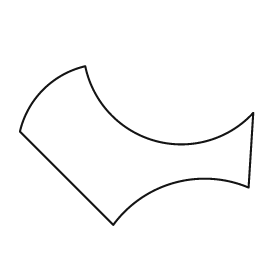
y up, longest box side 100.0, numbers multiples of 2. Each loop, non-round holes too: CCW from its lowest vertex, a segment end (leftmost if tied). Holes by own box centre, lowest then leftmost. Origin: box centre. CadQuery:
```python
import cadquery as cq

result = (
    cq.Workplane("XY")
    .moveTo(-10.0, -34.0)
    .threePointArc((16.0, -16.0), (48.0, -18.0))
    .lineTo(50.0, 14.0)
    .threePointArc((8.0, 2.0), (-22.0, 34.0))
    .threePointArc((-40.0, 24.0), (-50.0, 6.0))
    .close()
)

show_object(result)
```